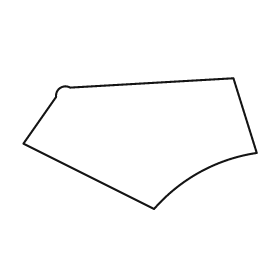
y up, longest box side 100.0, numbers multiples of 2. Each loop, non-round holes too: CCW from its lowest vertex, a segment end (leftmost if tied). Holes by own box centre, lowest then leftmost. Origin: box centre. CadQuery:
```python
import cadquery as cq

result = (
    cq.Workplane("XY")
    .moveTo(6.0, -28.0)
    .threePointArc((26.0, -12.0), (50.0, -4.0))
    .lineTo(40.0, 28.0)
    .lineTo(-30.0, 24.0)
    .threePointArc((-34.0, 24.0), (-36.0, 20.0))
    .lineTo(-50.0, 0.0)
    .close()
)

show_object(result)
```